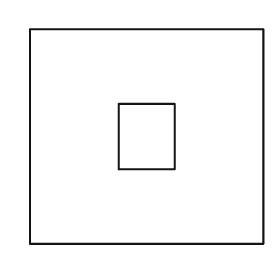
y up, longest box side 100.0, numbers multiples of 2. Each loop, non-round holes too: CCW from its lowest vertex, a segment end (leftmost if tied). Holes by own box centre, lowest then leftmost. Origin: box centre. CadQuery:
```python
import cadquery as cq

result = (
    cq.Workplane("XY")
    .moveTo(-50.0, -46.0)
    .lineTo(50.0, -46.0)
    .lineTo(50.0, 46.0)
    .lineTo(-50.0, 46.0)
    .close()
    .moveTo(-12.0, -14.0)
    .lineTo(12.0, -14.0)
    .lineTo(12.0, 14.0)
    .lineTo(-12.0, 14.0)
    .close()
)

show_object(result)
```